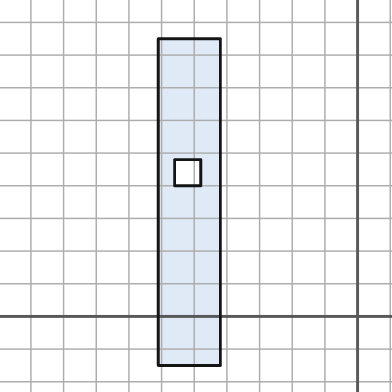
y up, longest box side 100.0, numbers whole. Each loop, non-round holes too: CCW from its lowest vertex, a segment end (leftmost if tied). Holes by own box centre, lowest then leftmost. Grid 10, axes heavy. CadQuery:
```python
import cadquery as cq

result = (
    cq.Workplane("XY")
    .moveTo(-61.0, -15.0)
    .lineTo(-42.0, -15.0)
    .lineTo(-42.0, 85.0)
    .lineTo(-61.0, 85.0)
    .close()
    .moveTo(-56.0, 40.0)
    .lineTo(-48.0, 40.0)
    .lineTo(-48.0, 48.0)
    .lineTo(-56.0, 48.0)
    .close()
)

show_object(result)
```